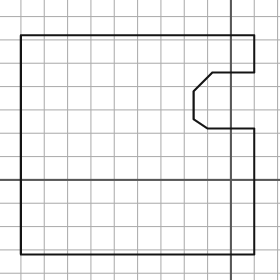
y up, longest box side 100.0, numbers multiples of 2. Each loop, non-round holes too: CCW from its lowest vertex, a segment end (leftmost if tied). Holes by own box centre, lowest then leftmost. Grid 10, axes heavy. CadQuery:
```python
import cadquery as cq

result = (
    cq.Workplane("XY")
    .moveTo(-90.0, -32.0)
    .lineTo(10.0, -32.0)
    .lineTo(10.0, 22.0)
    .lineTo(-10.0, 22.0)
    .lineTo(-16.0, 26.0)
    .lineTo(-16.0, 38.0)
    .lineTo(-8.0, 46.0)
    .lineTo(10.0, 46.0)
    .lineTo(10.0, 62.0)
    .lineTo(-90.0, 62.0)
    .close()
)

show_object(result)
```